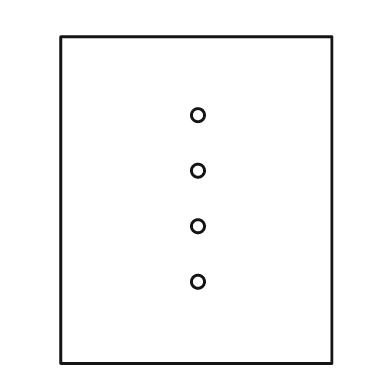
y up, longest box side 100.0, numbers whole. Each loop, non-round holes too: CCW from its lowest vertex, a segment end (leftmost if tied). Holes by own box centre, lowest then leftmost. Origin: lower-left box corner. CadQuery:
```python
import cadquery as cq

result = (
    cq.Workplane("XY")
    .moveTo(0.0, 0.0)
    .lineTo(83.0, 0.0)
    .lineTo(83.0, 100.0)
    .lineTo(0.0, 100.0)
    .close()
    .moveTo(42.0, 25.0)
    .circle(2.0)
    .moveTo(42.0, 42.0)
    .circle(2.0)
    .moveTo(42.0, 59.0)
    .circle(2.0)
    .moveTo(42.0, 76.0)
    .circle(2.0)
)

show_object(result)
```